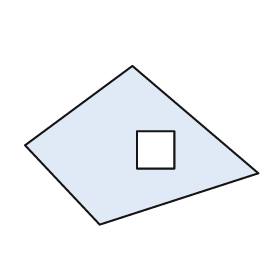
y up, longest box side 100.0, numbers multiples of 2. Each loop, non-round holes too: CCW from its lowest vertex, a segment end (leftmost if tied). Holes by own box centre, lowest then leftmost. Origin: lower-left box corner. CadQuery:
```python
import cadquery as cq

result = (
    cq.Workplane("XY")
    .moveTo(32.0, 0.0)
    .lineTo(100.0, 22.0)
    .lineTo(46.0, 68.0)
    .lineTo(0.0, 34.0)
    .close()
    .moveTo(48.0, 24.0)
    .lineTo(64.0, 24.0)
    .lineTo(64.0, 40.0)
    .lineTo(48.0, 40.0)
    .close()
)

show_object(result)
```